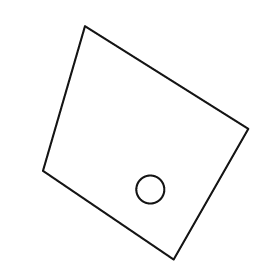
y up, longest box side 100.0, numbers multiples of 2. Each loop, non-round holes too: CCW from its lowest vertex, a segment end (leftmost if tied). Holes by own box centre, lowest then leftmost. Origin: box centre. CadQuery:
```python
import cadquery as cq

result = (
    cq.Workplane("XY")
    .moveTo(12.0, -50.0)
    .lineTo(44.0, 6.0)
    .lineTo(-26.0, 50.0)
    .lineTo(-44.0, -12.0)
    .close()
    .moveTo(2.0, -20.0)
    .circle(6.0)
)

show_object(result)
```